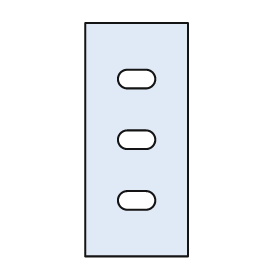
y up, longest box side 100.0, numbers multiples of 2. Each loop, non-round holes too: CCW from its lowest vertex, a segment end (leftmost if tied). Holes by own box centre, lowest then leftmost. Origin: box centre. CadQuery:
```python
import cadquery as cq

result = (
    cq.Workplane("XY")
    .moveTo(-22.0, -50.0)
    .lineTo(22.0, -50.0)
    .lineTo(22.0, 50.0)
    .lineTo(-22.0, 50.0)
    .close()
    .moveTo(-4.0, -30.0)
    .lineTo(4.0, -30.0)
    .threePointArc((8.0, -26.0), (4.0, -22.0))
    .lineTo(-4.0, -22.0)
    .threePointArc((-8.0, -26.0), (-4.0, -30.0))
    .close()
    .moveTo(-4.0, -4.0)
    .lineTo(4.0, -4.0)
    .threePointArc((8.0, 0.0), (4.0, 4.0))
    .lineTo(-4.0, 4.0)
    .threePointArc((-8.0, 0.0), (-4.0, -4.0))
    .close()
    .moveTo(-4.0, 22.0)
    .lineTo(4.0, 22.0)
    .threePointArc((8.0, 26.0), (4.0, 30.0))
    .lineTo(-4.0, 30.0)
    .threePointArc((-8.0, 26.0), (-4.0, 22.0))
    .close()
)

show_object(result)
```